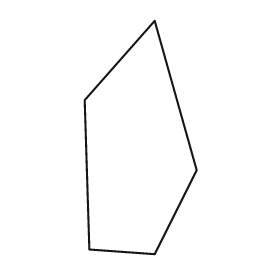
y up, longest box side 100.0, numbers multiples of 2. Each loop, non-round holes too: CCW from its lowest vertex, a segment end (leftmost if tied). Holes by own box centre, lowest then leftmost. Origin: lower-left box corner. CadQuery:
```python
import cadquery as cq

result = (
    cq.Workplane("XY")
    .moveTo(30.0, 0.0)
    .lineTo(48.0, 36.0)
    .lineTo(30.0, 100.0)
    .lineTo(0.0, 66.0)
    .lineTo(2.0, 2.0)
    .close()
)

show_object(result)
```